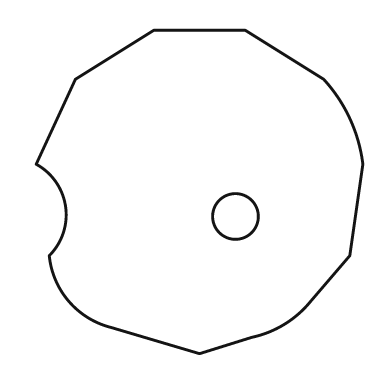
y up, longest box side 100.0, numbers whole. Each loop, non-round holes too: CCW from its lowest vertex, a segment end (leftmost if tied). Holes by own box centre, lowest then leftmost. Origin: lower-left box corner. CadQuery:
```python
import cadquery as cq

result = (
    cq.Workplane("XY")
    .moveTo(50.0, 0.0)
    .lineTo(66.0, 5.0)
    .threePointArc((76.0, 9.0), (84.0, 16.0))
    .lineTo(96.0, 30.0)
    .lineTo(100.0, 58.0)
    .threePointArc((96.0, 72.0), (88.0, 84.0))
    .lineTo(64.0, 99.0)
    .lineTo(36.0, 99.0)
    .lineTo(12.0, 84.0)
    .lineTo(0.0, 58.0)
    .threePointArc((9.0, 45.0), (4.0, 30.0))
    .threePointArc((10.0, 16.0), (23.0, 8.0))
    .close()
    .moveTo(61.0, 42.0)
    .circle(7.0)
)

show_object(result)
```